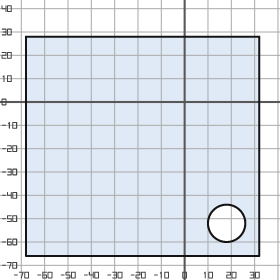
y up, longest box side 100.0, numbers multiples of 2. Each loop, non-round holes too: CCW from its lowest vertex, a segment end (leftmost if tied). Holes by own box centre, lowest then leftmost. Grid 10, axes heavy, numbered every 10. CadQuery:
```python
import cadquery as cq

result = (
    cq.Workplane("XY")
    .moveTo(-68.0, -66.0)
    .lineTo(32.0, -66.0)
    .lineTo(32.0, 28.0)
    .lineTo(-68.0, 28.0)
    .close()
    .moveTo(18.0, -52.0)
    .circle(8.0)
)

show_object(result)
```